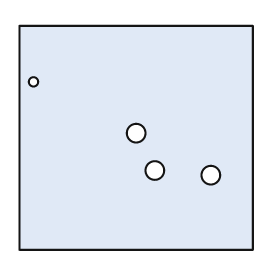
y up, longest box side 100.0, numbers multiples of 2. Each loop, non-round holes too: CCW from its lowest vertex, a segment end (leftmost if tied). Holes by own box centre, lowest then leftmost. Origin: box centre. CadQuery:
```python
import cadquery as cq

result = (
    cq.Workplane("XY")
    .moveTo(-50.0, -48.0)
    .lineTo(50.0, -48.0)
    .lineTo(50.0, 48.0)
    .lineTo(-50.0, 48.0)
    .close()
    .moveTo(32.0, -16.0)
    .circle(4.0)
    .moveTo(8.0, -14.0)
    .circle(4.0)
    .moveTo(0.0, 2.0)
    .circle(4.0)
    .moveTo(-44.0, 24.0)
    .circle(2.0)
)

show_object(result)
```